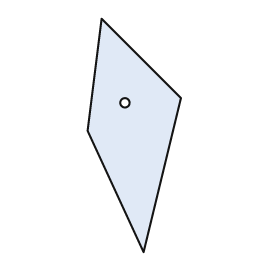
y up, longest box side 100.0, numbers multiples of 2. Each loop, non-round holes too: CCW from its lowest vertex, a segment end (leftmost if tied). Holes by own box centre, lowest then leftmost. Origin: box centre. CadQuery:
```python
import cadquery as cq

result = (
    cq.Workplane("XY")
    .moveTo(4.0, -50.0)
    .lineTo(20.0, 16.0)
    .lineTo(-14.0, 50.0)
    .lineTo(-20.0, 2.0)
    .close()
    .moveTo(-4.0, 14.0)
    .circle(2.0)
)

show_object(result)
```